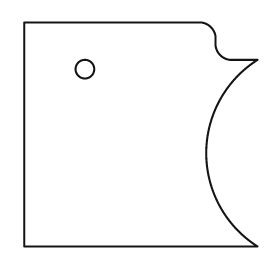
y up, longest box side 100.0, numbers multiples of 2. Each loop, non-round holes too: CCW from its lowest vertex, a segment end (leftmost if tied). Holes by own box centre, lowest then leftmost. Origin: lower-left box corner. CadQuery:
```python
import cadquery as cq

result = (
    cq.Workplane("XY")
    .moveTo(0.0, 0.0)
    .lineTo(100.0, 0.0)
    .threePointArc((78.0, 40.0), (100.0, 80.0))
    .lineTo(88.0, 80.0)
    .threePointArc((84.0, 82.0), (82.0, 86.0))
    .lineTo(82.0, 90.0)
    .threePointArc((80.0, 94.0), (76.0, 96.0))
    .lineTo(0.0, 96.0)
    .close()
    .moveTo(26.0, 76.0)
    .circle(4.0)
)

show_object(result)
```